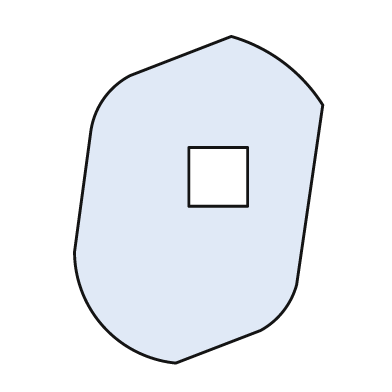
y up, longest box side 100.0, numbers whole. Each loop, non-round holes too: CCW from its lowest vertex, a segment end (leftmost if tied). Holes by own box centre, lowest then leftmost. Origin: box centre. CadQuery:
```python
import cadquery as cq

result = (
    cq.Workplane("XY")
    .moveTo(-7.0, -50.0)
    .lineTo(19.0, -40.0)
    .threePointArc((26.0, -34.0), (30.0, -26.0))
    .lineTo(38.0, 29.0)
    .threePointArc((26.0, 42.0), (10.0, 50.0))
    .lineTo(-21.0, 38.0)
    .threePointArc((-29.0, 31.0), (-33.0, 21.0))
    .lineTo(-38.0, -16.0)
    .threePointArc((-29.0, -39.0), (-7.0, -50.0))
    .close()
    .moveTo(-3.0, -2.0)
    .lineTo(15.0, -2.0)
    .lineTo(15.0, 16.0)
    .lineTo(-3.0, 16.0)
    .close()
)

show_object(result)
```